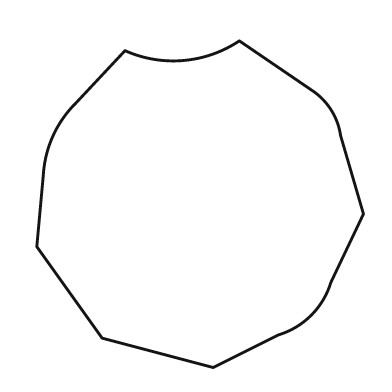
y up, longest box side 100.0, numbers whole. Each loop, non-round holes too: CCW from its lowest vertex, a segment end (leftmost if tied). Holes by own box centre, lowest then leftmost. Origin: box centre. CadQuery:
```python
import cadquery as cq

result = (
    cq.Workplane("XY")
    .moveTo(4.0, -50.0)
    .lineTo(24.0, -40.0)
    .threePointArc((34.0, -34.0), (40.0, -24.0))
    .lineTo(50.0, -3.0)
    .lineTo(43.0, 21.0)
    .threePointArc((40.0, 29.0), (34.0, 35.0))
    .lineTo(12.0, 50.0)
    .threePointArc((-5.0, 44.0), (-23.0, 47.0))
    .lineTo(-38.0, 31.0)
    .threePointArc((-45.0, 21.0), (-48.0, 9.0))
    .lineTo(-50.0, -13.0)
    .lineTo(-30.0, -41.0)
    .close()
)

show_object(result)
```